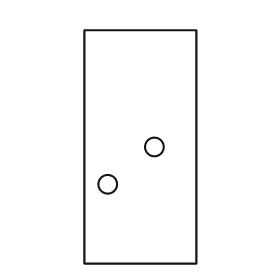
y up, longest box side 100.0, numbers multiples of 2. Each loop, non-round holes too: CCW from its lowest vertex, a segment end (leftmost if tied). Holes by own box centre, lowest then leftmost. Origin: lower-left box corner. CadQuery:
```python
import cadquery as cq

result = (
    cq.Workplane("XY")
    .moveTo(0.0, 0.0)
    .lineTo(48.0, 0.0)
    .lineTo(48.0, 100.0)
    .lineTo(0.0, 100.0)
    .close()
    .moveTo(10.0, 34.0)
    .circle(4.0)
    .moveTo(30.0, 50.0)
    .circle(4.0)
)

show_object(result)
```